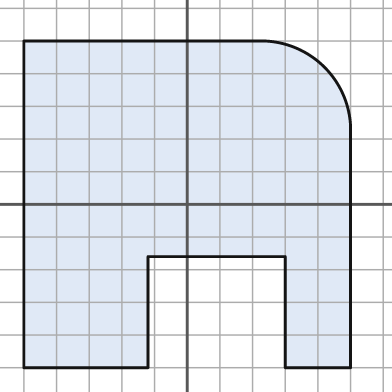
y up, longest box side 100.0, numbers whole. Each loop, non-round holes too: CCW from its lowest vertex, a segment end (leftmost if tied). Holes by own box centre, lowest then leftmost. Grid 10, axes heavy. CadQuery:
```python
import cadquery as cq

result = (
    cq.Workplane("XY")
    .moveTo(-50.0, -50.0)
    .lineTo(-12.0, -50.0)
    .lineTo(-12.0, -16.0)
    .lineTo(30.0, -16.0)
    .lineTo(30.0, -50.0)
    .lineTo(50.0, -50.0)
    .lineTo(50.0, 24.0)
    .threePointArc((42.0, 42.0), (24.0, 50.0))
    .lineTo(-50.0, 50.0)
    .close()
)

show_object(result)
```